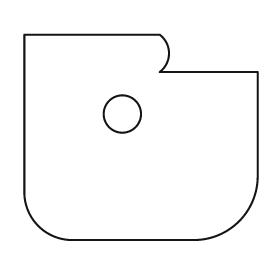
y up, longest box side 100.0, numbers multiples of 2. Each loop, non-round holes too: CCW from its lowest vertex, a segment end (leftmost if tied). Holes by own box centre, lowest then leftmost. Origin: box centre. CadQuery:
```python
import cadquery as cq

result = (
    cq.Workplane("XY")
    .moveTo(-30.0, -44.0)
    .lineTo(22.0, -44.0)
    .threePointArc((42.0, -36.0), (50.0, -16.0))
    .lineTo(50.0, 28.0)
    .lineTo(8.0, 28.0)
    .threePointArc((12.0, 36.0), (8.0, 44.0))
    .lineTo(-50.0, 44.0)
    .lineTo(-50.0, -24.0)
    .threePointArc((-44.0, -38.0), (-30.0, -44.0))
    .close()
    .moveTo(-8.0, 10.0)
    .circle(8.0)
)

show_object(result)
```